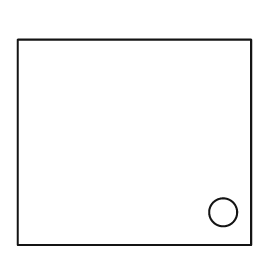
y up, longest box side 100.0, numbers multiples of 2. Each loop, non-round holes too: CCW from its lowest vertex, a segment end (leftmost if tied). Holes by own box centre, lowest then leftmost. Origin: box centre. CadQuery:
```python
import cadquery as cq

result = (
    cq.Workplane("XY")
    .moveTo(-50.0, -44.0)
    .lineTo(50.0, -44.0)
    .lineTo(50.0, 44.0)
    .lineTo(-50.0, 44.0)
    .close()
    .moveTo(38.0, -30.0)
    .circle(6.0)
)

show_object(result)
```